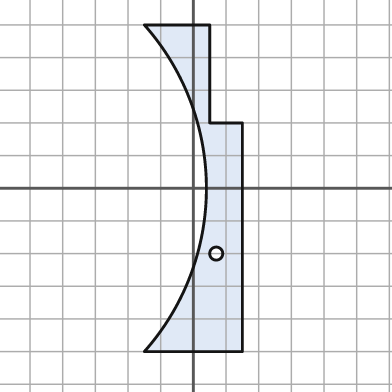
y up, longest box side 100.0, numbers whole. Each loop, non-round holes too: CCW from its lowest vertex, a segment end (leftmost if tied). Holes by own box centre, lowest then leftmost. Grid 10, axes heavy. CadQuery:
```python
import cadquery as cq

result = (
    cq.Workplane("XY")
    .moveTo(-15.0, -50.0)
    .lineTo(15.0, -50.0)
    .lineTo(15.0, 20.0)
    .lineTo(5.0, 20.0)
    .lineTo(5.0, 50.0)
    .lineTo(-15.0, 50.0)
    .threePointArc((4.0, 0.0), (-15.0, -50.0))
    .close()
    .moveTo(7.0, -20.0)
    .circle(2.0)
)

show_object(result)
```